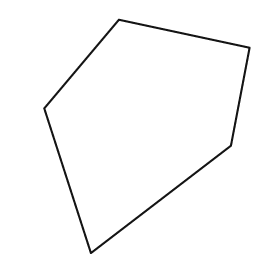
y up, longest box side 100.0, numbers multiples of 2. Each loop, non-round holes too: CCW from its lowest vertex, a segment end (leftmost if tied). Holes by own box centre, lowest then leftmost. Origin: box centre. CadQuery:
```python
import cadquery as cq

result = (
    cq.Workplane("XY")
    .moveTo(-24.0, -50.0)
    .lineTo(36.0, -4.0)
    .lineTo(44.0, 38.0)
    .lineTo(-12.0, 50.0)
    .lineTo(-44.0, 12.0)
    .close()
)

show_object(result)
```